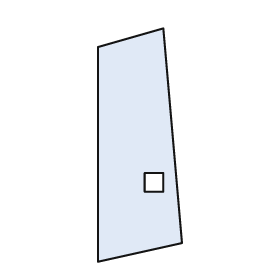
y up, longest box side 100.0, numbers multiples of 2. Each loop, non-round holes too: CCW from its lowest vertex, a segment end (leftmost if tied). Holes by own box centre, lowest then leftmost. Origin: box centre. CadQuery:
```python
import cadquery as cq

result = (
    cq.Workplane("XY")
    .moveTo(-18.0, -50.0)
    .lineTo(18.0, -42.0)
    .lineTo(10.0, 50.0)
    .lineTo(-18.0, 42.0)
    .close()
    .moveTo(2.0, -20.0)
    .lineTo(10.0, -20.0)
    .lineTo(10.0, -12.0)
    .lineTo(2.0, -12.0)
    .close()
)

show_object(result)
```